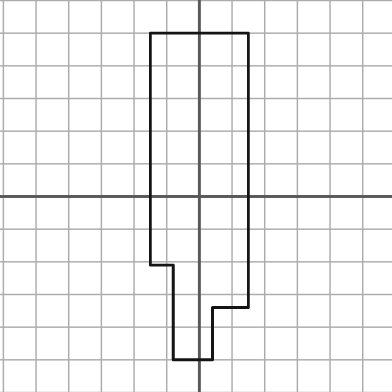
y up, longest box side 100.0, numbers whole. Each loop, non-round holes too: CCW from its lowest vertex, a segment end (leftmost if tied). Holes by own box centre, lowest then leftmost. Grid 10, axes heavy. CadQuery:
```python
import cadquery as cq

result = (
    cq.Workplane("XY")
    .moveTo(-8.0, -50.0)
    .lineTo(4.0, -50.0)
    .lineTo(4.0, -34.0)
    .lineTo(15.0, -34.0)
    .lineTo(15.0, 50.0)
    .lineTo(-15.0, 50.0)
    .lineTo(-15.0, -21.0)
    .lineTo(-8.0, -21.0)
    .close()
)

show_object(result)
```